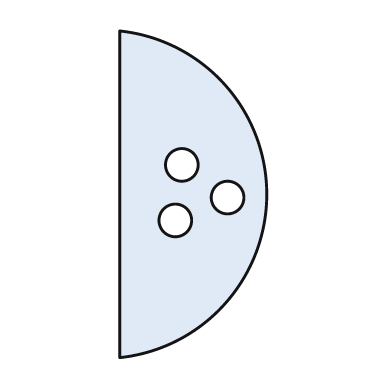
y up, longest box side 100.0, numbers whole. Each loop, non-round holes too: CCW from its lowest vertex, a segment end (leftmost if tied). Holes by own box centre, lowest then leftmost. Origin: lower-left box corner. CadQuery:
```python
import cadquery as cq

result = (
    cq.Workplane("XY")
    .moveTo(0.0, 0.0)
    .threePointArc((45.0, 50.0), (0.0, 100.0))
    .close()
    .moveTo(17.0, 42.0)
    .circle(5.0)
    .moveTo(33.0, 49.0)
    .circle(5.0)
    .moveTo(19.0, 59.0)
    .circle(5.0)
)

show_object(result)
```